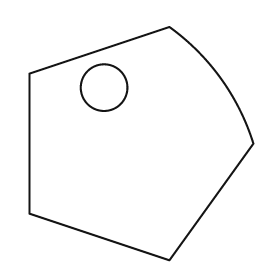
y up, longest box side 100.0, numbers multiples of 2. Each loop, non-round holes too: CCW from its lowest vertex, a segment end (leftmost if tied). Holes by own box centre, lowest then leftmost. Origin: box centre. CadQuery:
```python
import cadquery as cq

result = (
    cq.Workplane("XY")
    .moveTo(12.0, -50.0)
    .lineTo(48.0, 0.0)
    .threePointArc((34.0, 28.0), (12.0, 50.0))
    .lineTo(-48.0, 30.0)
    .lineTo(-48.0, -30.0)
    .close()
    .moveTo(-16.0, 24.0)
    .circle(10.0)
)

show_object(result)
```